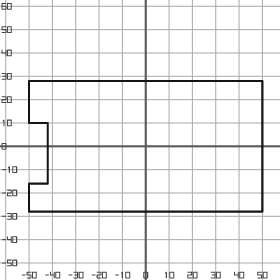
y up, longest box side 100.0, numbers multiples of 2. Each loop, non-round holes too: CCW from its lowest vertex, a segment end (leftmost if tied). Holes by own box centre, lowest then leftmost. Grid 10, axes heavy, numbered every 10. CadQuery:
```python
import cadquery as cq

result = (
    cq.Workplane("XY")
    .moveTo(-50.0, -28.0)
    .lineTo(50.0, -28.0)
    .lineTo(50.0, 28.0)
    .lineTo(-50.0, 28.0)
    .lineTo(-50.0, 10.0)
    .lineTo(-42.0, 10.0)
    .lineTo(-42.0, -16.0)
    .lineTo(-50.0, -16.0)
    .close()
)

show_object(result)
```